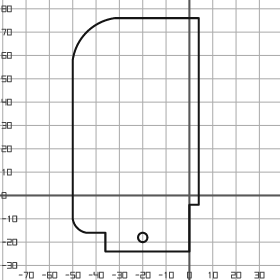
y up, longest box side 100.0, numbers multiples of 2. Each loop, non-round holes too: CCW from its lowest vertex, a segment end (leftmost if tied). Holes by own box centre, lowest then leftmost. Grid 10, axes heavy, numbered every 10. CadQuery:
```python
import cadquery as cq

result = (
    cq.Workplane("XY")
    .moveTo(-36.0, -24.0)
    .lineTo(0.0, -24.0)
    .lineTo(0.0, -4.0)
    .lineTo(4.0, -4.0)
    .lineTo(4.0, 76.0)
    .lineTo(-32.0, 76.0)
    .threePointArc((-44.0, 70.0), (-50.0, 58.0))
    .lineTo(-50.0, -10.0)
    .threePointArc((-48.0, -14.0), (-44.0, -16.0))
    .lineTo(-36.0, -16.0)
    .close()
    .moveTo(-20.0, -18.0)
    .circle(2.0)
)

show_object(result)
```